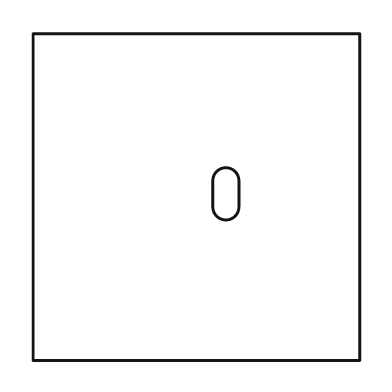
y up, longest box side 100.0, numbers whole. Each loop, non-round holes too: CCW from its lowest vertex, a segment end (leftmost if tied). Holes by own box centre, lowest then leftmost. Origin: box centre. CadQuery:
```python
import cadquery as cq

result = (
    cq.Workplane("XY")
    .moveTo(-50.0, -50.0)
    .lineTo(50.0, -50.0)
    .lineTo(50.0, 50.0)
    .lineTo(-50.0, 50.0)
    .close()
    .moveTo(5.0, -3.0)
    .threePointArc((9.0, -7.0), (13.0, -3.0))
    .lineTo(13.0, 5.0)
    .threePointArc((9.0, 9.0), (5.0, 5.0))
    .close()
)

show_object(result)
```